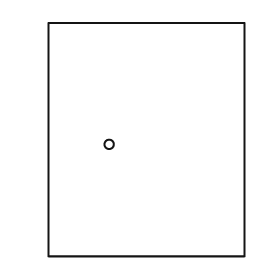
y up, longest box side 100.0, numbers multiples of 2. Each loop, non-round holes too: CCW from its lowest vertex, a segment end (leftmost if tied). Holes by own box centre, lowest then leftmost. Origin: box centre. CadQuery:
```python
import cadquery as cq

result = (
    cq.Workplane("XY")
    .moveTo(-42.0, -50.0)
    .lineTo(42.0, -50.0)
    .lineTo(42.0, 50.0)
    .lineTo(-42.0, 50.0)
    .close()
    .moveTo(-16.0, -2.0)
    .circle(2.0)
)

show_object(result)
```